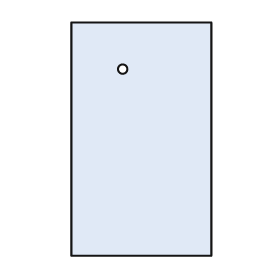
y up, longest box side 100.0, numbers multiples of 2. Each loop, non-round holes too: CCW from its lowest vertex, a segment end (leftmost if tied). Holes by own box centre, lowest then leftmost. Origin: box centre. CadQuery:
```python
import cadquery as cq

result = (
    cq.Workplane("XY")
    .moveTo(-30.0, -50.0)
    .lineTo(30.0, -50.0)
    .lineTo(30.0, 50.0)
    .lineTo(-30.0, 50.0)
    .close()
    .moveTo(-8.0, 30.0)
    .circle(2.0)
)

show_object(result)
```